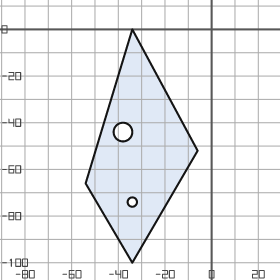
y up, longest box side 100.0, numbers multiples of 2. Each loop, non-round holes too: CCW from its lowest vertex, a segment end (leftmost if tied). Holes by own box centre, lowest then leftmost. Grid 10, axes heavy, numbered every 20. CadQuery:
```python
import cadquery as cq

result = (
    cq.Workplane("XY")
    .moveTo(-34.0, -100.0)
    .lineTo(-6.0, -52.0)
    .lineTo(-34.0, 0.0)
    .lineTo(-54.0, -66.0)
    .close()
    .moveTo(-34.0, -74.0)
    .circle(2.0)
    .moveTo(-38.0, -44.0)
    .circle(4.0)
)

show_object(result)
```